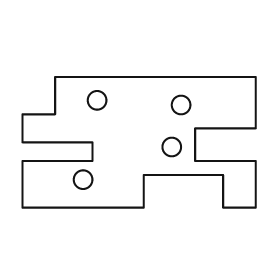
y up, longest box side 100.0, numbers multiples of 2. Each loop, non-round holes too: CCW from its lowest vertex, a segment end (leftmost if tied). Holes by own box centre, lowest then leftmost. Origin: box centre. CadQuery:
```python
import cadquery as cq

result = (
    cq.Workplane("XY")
    .moveTo(-50.0, -28.0)
    .lineTo(2.0, -28.0)
    .lineTo(2.0, -14.0)
    .lineTo(36.0, -14.0)
    .lineTo(36.0, -28.0)
    .lineTo(50.0, -28.0)
    .lineTo(50.0, -8.0)
    .lineTo(24.0, -8.0)
    .lineTo(24.0, 6.0)
    .lineTo(50.0, 6.0)
    .lineTo(50.0, 28.0)
    .lineTo(-36.0, 28.0)
    .lineTo(-36.0, 12.0)
    .lineTo(-50.0, 12.0)
    .lineTo(-50.0, 0.0)
    .lineTo(-20.0, 0.0)
    .lineTo(-20.0, -8.0)
    .lineTo(-50.0, -8.0)
    .close()
    .moveTo(-24.0, -16.0)
    .circle(4.0)
    .moveTo(14.0, -2.0)
    .circle(4.0)
    .moveTo(18.0, 16.0)
    .circle(4.0)
    .moveTo(-18.0, 18.0)
    .circle(4.0)
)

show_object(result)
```